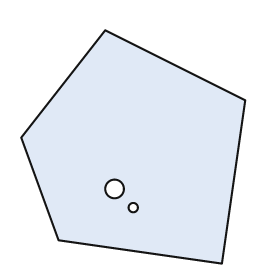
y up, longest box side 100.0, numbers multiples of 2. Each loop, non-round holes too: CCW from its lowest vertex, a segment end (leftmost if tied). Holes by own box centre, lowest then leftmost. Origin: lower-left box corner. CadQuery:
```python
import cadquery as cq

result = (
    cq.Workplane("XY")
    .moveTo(86.0, 0.0)
    .lineTo(96.0, 70.0)
    .lineTo(36.0, 100.0)
    .lineTo(0.0, 54.0)
    .lineTo(16.0, 10.0)
    .close()
    .moveTo(48.0, 24.0)
    .circle(2.0)
    .moveTo(40.0, 32.0)
    .circle(4.0)
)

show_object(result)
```